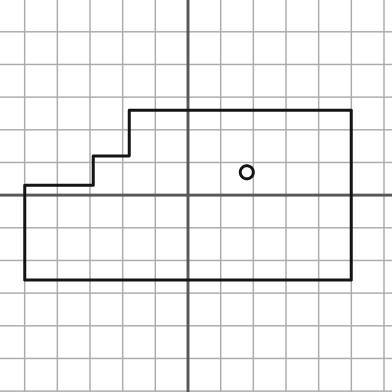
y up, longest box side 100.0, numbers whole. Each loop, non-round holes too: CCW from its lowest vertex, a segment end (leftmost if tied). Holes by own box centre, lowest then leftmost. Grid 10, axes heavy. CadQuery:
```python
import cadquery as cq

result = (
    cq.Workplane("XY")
    .moveTo(-50.0, -26.0)
    .lineTo(50.0, -26.0)
    .lineTo(50.0, 26.0)
    .lineTo(-18.0, 26.0)
    .lineTo(-18.0, 12.0)
    .lineTo(-29.0, 12.0)
    .lineTo(-29.0, 3.0)
    .lineTo(-50.0, 3.0)
    .close()
    .moveTo(18.0, 7.0)
    .circle(2.0)
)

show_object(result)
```